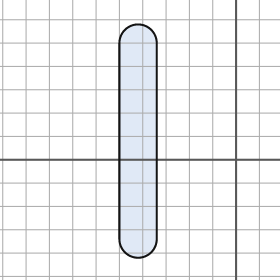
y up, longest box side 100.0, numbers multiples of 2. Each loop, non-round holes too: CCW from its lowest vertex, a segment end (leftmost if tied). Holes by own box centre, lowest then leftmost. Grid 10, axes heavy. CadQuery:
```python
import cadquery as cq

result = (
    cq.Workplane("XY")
    .moveTo(-50.0, -34.0)
    .threePointArc((-42.0, -42.0), (-34.0, -34.0))
    .lineTo(-34.0, 50.0)
    .threePointArc((-42.0, 58.0), (-50.0, 50.0))
    .close()
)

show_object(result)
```